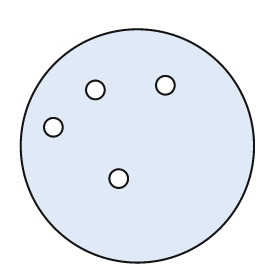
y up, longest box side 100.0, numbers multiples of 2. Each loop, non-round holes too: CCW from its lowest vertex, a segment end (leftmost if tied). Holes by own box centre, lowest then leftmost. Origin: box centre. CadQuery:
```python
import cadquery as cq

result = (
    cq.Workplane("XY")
    .moveTo(0.0, 0.0)
    .circle(50.0)
    .moveTo(-8.0, -14.0)
    .circle(4.0)
    .moveTo(-36.0, 8.0)
    .circle(4.0)
    .moveTo(-18.0, 24.0)
    .circle(4.0)
    .moveTo(12.0, 26.0)
    .circle(4.0)
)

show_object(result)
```